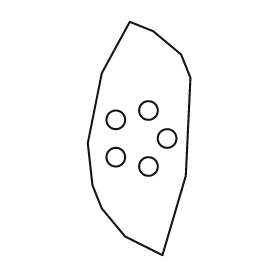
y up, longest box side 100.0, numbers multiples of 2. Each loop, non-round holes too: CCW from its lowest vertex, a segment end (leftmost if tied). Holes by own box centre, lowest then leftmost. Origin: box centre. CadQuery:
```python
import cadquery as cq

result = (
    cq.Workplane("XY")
    .moveTo(10.0, -50.0)
    .lineTo(20.0, -16.0)
    .lineTo(22.0, 26.0)
    .lineTo(18.0, 36.0)
    .lineTo(6.0, 46.0)
    .lineTo(-4.0, 50.0)
    .lineTo(-16.0, 28.0)
    .lineTo(-22.0, -2.0)
    .lineTo(-20.0, -20.0)
    .lineTo(-16.0, -30.0)
    .lineTo(-6.0, -42.0)
    .close()
    .moveTo(4.0, -12.0)
    .circle(4.0)
    .moveTo(-10.0, -8.0)
    .circle(4.0)
    .moveTo(12.0, 0.0)
    .circle(4.0)
    .moveTo(-10.0, 8.0)
    .circle(4.0)
    .moveTo(4.0, 12.0)
    .circle(4.0)
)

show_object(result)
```